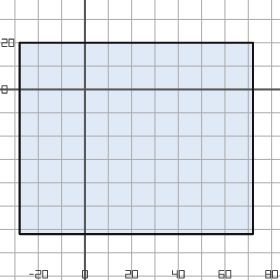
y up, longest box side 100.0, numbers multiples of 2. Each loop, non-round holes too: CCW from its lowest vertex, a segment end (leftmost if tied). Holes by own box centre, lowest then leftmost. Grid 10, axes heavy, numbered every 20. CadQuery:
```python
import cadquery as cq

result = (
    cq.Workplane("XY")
    .moveTo(-28.0, -62.0)
    .lineTo(72.0, -62.0)
    .lineTo(72.0, 20.0)
    .lineTo(-28.0, 20.0)
    .close()
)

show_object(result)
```